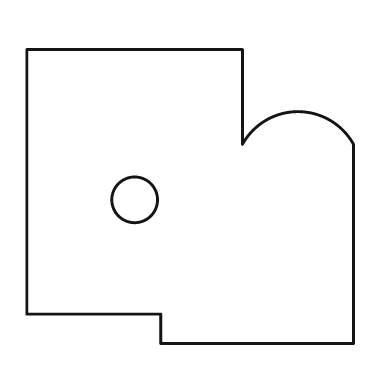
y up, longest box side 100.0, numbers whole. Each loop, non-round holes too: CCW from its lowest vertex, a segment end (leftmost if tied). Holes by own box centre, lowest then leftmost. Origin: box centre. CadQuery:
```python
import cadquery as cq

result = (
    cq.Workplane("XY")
    .moveTo(-9.0, -45.0)
    .lineTo(50.0, -45.0)
    .lineTo(50.0, 16.0)
    .threePointArc((33.0, 26.0), (16.0, 16.0))
    .lineTo(16.0, 45.0)
    .lineTo(-50.0, 45.0)
    .lineTo(-50.0, -36.0)
    .lineTo(-9.0, -36.0)
    .close()
    .moveTo(-17.0, -1.0)
    .circle(7.0)
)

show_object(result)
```